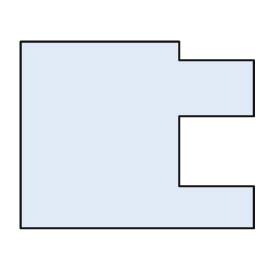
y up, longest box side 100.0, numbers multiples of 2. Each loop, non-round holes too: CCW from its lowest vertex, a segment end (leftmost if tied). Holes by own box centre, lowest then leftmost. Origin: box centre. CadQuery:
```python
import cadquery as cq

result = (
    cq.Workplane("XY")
    .moveTo(-50.0, -40.0)
    .lineTo(50.0, -40.0)
    .lineTo(50.0, -22.0)
    .lineTo(18.0, -22.0)
    .lineTo(18.0, 8.0)
    .lineTo(50.0, 8.0)
    .lineTo(50.0, 32.0)
    .lineTo(18.0, 32.0)
    .lineTo(18.0, 40.0)
    .lineTo(-50.0, 40.0)
    .close()
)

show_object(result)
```